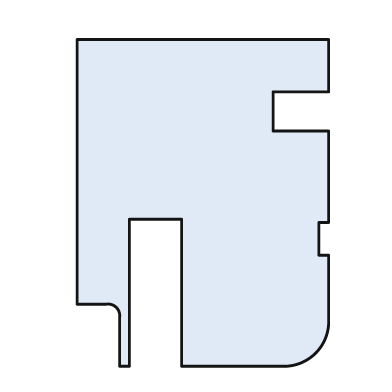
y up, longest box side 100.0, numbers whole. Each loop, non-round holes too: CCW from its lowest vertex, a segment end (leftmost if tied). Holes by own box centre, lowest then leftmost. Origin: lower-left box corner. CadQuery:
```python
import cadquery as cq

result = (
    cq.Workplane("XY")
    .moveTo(13.0, 0.0)
    .lineTo(16.0, 0.0)
    .lineTo(16.0, 45.0)
    .lineTo(32.0, 45.0)
    .lineTo(32.0, 0.0)
    .lineTo(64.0, 0.0)
    .threePointArc((73.0, 4.0), (77.0, 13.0))
    .lineTo(77.0, 34.0)
    .lineTo(74.0, 34.0)
    .lineTo(74.0, 44.0)
    .lineTo(77.0, 44.0)
    .lineTo(77.0, 72.0)
    .lineTo(60.0, 72.0)
    .lineTo(60.0, 84.0)
    .lineTo(77.0, 84.0)
    .lineTo(77.0, 100.0)
    .lineTo(0.0, 100.0)
    .lineTo(0.0, 19.0)
    .lineTo(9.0, 19.0)
    .threePointArc((12.0, 18.0), (13.0, 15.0))
    .close()
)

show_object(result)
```